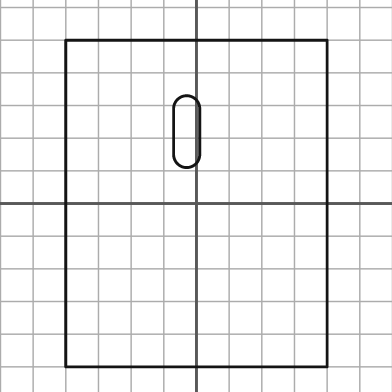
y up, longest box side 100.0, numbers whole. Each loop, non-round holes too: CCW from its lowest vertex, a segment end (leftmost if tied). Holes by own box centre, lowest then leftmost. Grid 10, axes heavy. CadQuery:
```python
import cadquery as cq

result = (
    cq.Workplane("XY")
    .moveTo(-40.0, -50.0)
    .lineTo(40.0, -50.0)
    .lineTo(40.0, 50.0)
    .lineTo(-40.0, 50.0)
    .close()
    .moveTo(-7.0, 15.0)
    .threePointArc((-3.0, 11.0), (1.0, 15.0))
    .lineTo(1.0, 29.0)
    .threePointArc((-3.0, 33.0), (-7.0, 29.0))
    .close()
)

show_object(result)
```